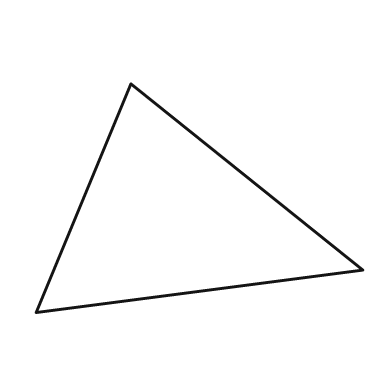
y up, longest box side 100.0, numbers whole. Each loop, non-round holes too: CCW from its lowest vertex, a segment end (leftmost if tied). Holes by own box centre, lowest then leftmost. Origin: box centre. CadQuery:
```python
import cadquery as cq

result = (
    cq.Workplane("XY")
    .moveTo(-50.0, -35.0)
    .lineTo(50.0, -22.0)
    .lineTo(-21.0, 35.0)
    .close()
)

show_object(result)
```